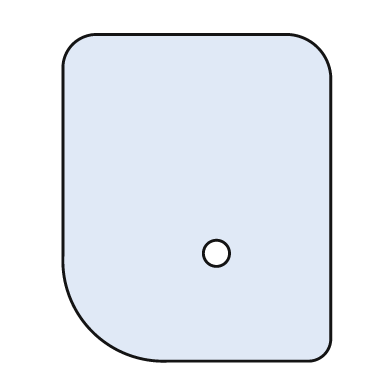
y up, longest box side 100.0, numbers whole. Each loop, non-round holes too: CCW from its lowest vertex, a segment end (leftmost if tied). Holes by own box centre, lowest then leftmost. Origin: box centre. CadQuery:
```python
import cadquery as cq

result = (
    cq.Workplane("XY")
    .moveTo(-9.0, -50.0)
    .lineTo(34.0, -50.0)
    .threePointArc((39.0, -48.0), (41.0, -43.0))
    .lineTo(41.0, 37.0)
    .threePointArc((37.0, 46.0), (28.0, 50.0))
    .lineTo(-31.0, 50.0)
    .threePointArc((-38.0, 47.0), (-41.0, 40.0))
    .lineTo(-41.0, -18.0)
    .threePointArc((-32.0, -41.0), (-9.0, -50.0))
    .close()
    .moveTo(6.0, -17.0)
    .circle(4.0)
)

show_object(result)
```